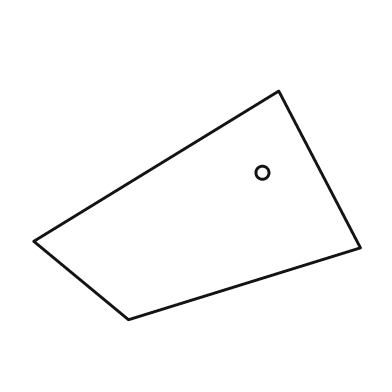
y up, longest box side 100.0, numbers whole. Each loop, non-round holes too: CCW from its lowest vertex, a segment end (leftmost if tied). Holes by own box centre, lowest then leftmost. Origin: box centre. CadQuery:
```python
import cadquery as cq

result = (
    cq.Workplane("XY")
    .moveTo(-21.0, -35.0)
    .lineTo(50.0, -13.0)
    .lineTo(25.0, 35.0)
    .lineTo(-50.0, -11.0)
    .close()
    .moveTo(20.0, 10.0)
    .circle(2.0)
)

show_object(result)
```